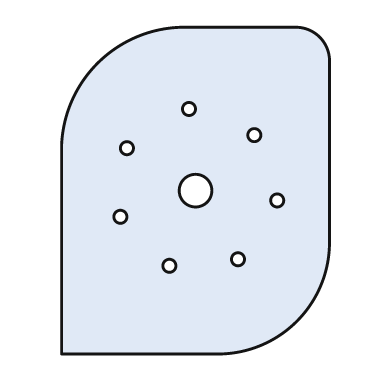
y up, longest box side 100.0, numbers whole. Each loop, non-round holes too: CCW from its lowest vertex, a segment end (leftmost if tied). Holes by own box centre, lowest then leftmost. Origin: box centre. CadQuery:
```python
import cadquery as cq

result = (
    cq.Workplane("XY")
    .moveTo(-41.0, -50.0)
    .lineTo(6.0, -50.0)
    .threePointArc((31.0, -40.0), (41.0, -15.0))
    .lineTo(41.0, 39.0)
    .threePointArc((38.0, 47.0), (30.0, 50.0))
    .lineTo(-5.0, 50.0)
    .threePointArc((-30.0, 39.0), (-41.0, 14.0))
    .close()
    .moveTo(-8.0, -23.0)
    .circle(2.0)
    .moveTo(13.0, -21.0)
    .circle(2.0)
    .moveTo(-23.0, -8.0)
    .circle(2.0)
    .moveTo(25.0, -3.0)
    .circle(2.0)
    .moveTo(0.0, 0.0)
    .circle(5.0)
    .moveTo(-21.0, 13.0)
    .circle(2.0)
    .moveTo(18.0, 17.0)
    .circle(2.0)
    .moveTo(-2.0, 25.0)
    .circle(2.0)
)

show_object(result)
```